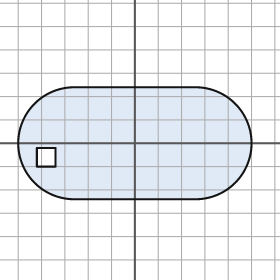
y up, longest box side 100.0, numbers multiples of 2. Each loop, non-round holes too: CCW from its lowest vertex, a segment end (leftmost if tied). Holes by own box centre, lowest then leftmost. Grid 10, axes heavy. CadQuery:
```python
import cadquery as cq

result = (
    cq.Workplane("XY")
    .moveTo(-26.0, -24.0)
    .lineTo(26.0, -24.0)
    .threePointArc((50.0, 0.0), (26.0, 24.0))
    .lineTo(-26.0, 24.0)
    .threePointArc((-50.0, 0.0), (-26.0, -24.0))
    .close()
    .moveTo(-42.0, -10.0)
    .lineTo(-34.0, -10.0)
    .lineTo(-34.0, -2.0)
    .lineTo(-42.0, -2.0)
    .close()
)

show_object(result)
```